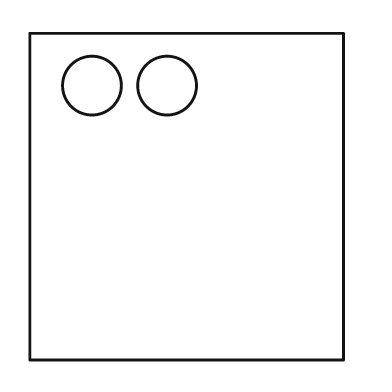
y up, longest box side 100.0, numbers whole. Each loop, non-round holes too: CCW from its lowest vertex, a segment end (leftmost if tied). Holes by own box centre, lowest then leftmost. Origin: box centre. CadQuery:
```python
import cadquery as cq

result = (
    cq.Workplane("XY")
    .moveTo(-48.0, -50.0)
    .lineTo(48.0, -50.0)
    .lineTo(48.0, 50.0)
    .lineTo(-48.0, 50.0)
    .close()
    .moveTo(-29.0, 34.0)
    .circle(9.0)
    .moveTo(-6.0, 34.0)
    .circle(9.0)
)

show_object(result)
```